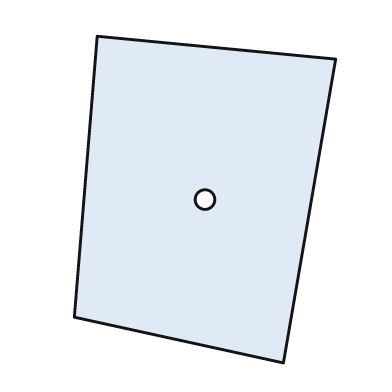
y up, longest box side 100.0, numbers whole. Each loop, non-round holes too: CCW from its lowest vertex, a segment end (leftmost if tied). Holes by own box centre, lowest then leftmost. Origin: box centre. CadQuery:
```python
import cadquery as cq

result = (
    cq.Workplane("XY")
    .moveTo(24.0, -50.0)
    .lineTo(40.0, 43.0)
    .lineTo(-33.0, 50.0)
    .lineTo(-40.0, -36.0)
    .close()
    .moveTo(0.0, 0.0)
    .circle(3.0)
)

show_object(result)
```